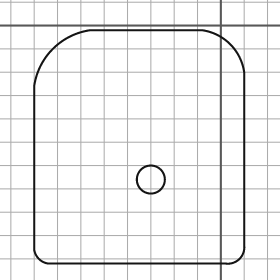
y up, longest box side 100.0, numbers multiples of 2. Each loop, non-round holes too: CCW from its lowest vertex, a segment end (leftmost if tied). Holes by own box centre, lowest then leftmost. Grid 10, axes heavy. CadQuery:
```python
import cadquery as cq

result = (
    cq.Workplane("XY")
    .moveTo(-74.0, -102.0)
    .lineTo(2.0, -102.0)
    .threePointArc((8.0, -100.0), (10.0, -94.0))
    .lineTo(10.0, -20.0)
    .threePointArc((4.0, -8.0), (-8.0, -2.0))
    .lineTo(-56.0, -2.0)
    .threePointArc((-72.0, -10.0), (-80.0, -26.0))
    .lineTo(-80.0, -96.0)
    .threePointArc((-78.0, -100.0), (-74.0, -102.0))
    .close()
    .moveTo(-30.0, -66.0)
    .circle(6.0)
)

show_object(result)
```